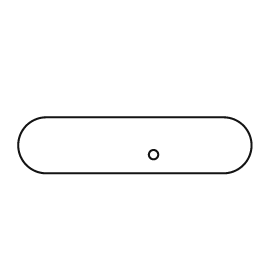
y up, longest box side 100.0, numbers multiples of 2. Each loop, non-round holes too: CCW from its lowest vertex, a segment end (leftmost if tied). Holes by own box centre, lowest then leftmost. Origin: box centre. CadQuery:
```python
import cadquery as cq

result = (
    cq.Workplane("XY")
    .moveTo(-38.0, -12.0)
    .lineTo(38.0, -12.0)
    .threePointArc((50.0, 0.0), (38.0, 12.0))
    .lineTo(-38.0, 12.0)
    .threePointArc((-50.0, 0.0), (-38.0, -12.0))
    .close()
    .moveTo(8.0, -4.0)
    .circle(2.0)
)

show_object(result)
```